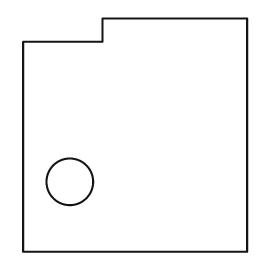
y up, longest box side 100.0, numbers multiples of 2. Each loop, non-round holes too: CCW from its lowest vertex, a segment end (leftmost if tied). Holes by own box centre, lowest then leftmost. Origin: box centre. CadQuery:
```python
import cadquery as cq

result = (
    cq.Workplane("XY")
    .moveTo(-48.0, -50.0)
    .lineTo(48.0, -50.0)
    .lineTo(48.0, 50.0)
    .lineTo(-14.0, 50.0)
    .lineTo(-14.0, 40.0)
    .lineTo(-48.0, 40.0)
    .close()
    .moveTo(-28.0, -20.0)
    .circle(10.0)
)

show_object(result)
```